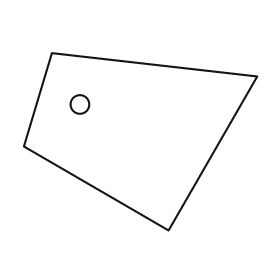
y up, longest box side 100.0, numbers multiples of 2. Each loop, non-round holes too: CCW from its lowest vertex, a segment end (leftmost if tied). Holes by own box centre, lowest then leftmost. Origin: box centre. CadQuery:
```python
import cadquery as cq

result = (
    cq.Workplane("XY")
    .moveTo(12.0, -38.0)
    .lineTo(50.0, 28.0)
    .lineTo(-38.0, 38.0)
    .lineTo(-50.0, -2.0)
    .close()
    .moveTo(-26.0, 16.0)
    .circle(4.0)
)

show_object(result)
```